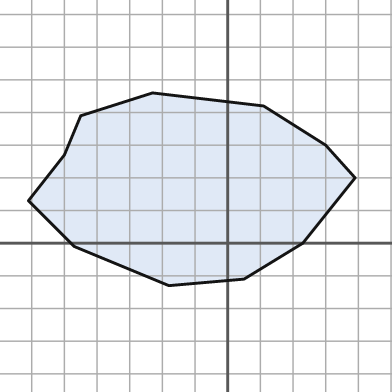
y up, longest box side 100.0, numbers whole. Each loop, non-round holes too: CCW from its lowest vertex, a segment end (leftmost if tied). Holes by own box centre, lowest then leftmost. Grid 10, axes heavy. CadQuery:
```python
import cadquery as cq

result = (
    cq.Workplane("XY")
    .moveTo(-18.0, -13.0)
    .lineTo(5.0, -11.0)
    .lineTo(23.0, 0.0)
    .lineTo(39.0, 20.0)
    .lineTo(30.0, 30.0)
    .lineTo(11.0, 42.0)
    .lineTo(-23.0, 46.0)
    .lineTo(-45.0, 39.0)
    .lineTo(-50.0, 27.0)
    .lineTo(-61.0, 13.0)
    .lineTo(-47.0, -1.0)
    .close()
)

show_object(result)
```